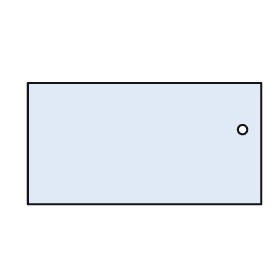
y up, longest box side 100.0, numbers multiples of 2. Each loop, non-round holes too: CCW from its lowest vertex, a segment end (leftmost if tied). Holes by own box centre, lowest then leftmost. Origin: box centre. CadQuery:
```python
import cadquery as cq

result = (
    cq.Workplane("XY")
    .moveTo(-50.0, -26.0)
    .lineTo(50.0, -26.0)
    .lineTo(50.0, 26.0)
    .lineTo(-50.0, 26.0)
    .close()
    .moveTo(42.0, 6.0)
    .circle(2.0)
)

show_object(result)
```